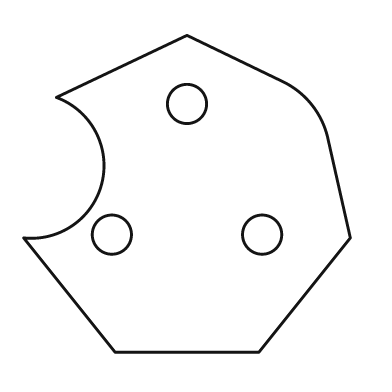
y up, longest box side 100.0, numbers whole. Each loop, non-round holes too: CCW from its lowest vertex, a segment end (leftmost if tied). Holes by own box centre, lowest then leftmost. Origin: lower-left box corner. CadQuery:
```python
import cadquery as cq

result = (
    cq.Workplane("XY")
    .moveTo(28.0, 0.0)
    .lineTo(72.0, 0.0)
    .lineTo(100.0, 35.0)
    .lineTo(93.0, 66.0)
    .threePointArc((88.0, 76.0), (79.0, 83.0))
    .lineTo(50.0, 97.0)
    .lineTo(10.0, 78.0)
    .threePointArc((24.0, 52.0), (0.0, 35.0))
    .close()
    .moveTo(27.0, 36.0)
    .circle(6.0)
    .moveTo(73.0, 36.0)
    .circle(6.0)
    .moveTo(50.0, 76.0)
    .circle(6.0)
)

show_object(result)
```